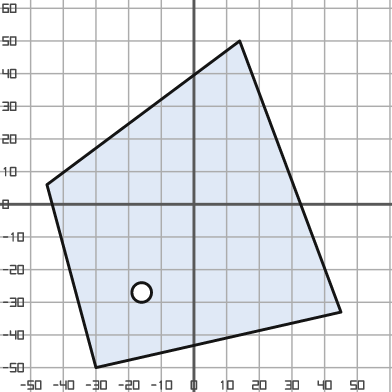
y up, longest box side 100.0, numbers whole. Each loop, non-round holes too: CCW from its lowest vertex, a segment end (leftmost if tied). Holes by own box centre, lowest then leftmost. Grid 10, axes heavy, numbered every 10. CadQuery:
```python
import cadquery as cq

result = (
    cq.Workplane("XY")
    .moveTo(-30.0, -50.0)
    .lineTo(45.0, -33.0)
    .lineTo(14.0, 50.0)
    .lineTo(-45.0, 6.0)
    .close()
    .moveTo(-16.0, -27.0)
    .circle(3.0)
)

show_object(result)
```